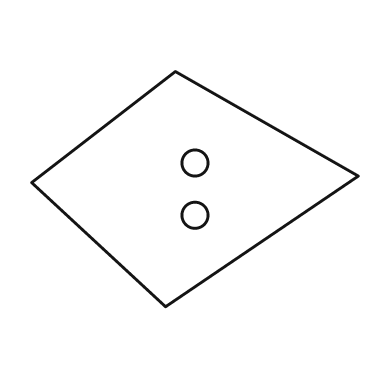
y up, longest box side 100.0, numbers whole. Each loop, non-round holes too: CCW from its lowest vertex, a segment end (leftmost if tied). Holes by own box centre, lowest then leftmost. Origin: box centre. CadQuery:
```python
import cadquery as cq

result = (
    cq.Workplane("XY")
    .moveTo(-9.0, -36.0)
    .lineTo(50.0, 4.0)
    .lineTo(-6.0, 36.0)
    .lineTo(-50.0, 2.0)
    .close()
    .moveTo(0.0, -8.0)
    .circle(4.0)
    .moveTo(0.0, 8.0)
    .circle(4.0)
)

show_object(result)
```